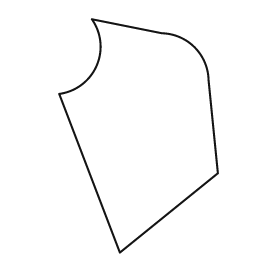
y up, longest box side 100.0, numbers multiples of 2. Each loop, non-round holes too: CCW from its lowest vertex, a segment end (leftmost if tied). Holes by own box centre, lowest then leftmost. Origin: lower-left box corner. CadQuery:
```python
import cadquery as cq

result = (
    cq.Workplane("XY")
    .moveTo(26.0, 0.0)
    .lineTo(68.0, 34.0)
    .lineTo(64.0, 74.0)
    .threePointArc((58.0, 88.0), (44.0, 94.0))
    .lineTo(14.0, 100.0)
    .threePointArc((16.0, 80.0), (0.0, 68.0))
    .close()
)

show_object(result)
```